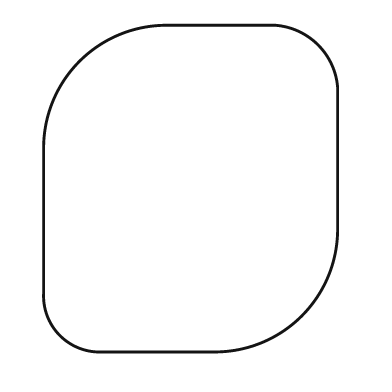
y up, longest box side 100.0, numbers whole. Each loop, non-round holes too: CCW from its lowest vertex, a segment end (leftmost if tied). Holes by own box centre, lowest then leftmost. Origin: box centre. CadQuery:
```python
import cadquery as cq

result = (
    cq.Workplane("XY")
    .moveTo(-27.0, -50.0)
    .lineTo(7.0, -50.0)
    .threePointArc((34.0, -39.0), (45.0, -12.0))
    .lineTo(45.0, 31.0)
    .threePointArc((39.0, 44.0), (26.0, 50.0))
    .lineTo(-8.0, 50.0)
    .threePointArc((-34.0, 39.0), (-45.0, 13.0))
    .lineTo(-45.0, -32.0)
    .threePointArc((-40.0, -45.0), (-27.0, -50.0))
    .close()
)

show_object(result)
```